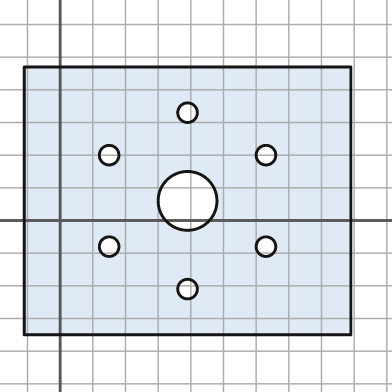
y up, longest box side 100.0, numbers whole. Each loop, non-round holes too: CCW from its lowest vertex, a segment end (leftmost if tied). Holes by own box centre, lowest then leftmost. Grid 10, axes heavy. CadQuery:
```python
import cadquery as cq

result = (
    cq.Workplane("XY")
    .moveTo(-11.0, -35.0)
    .lineTo(89.0, -35.0)
    .lineTo(89.0, 47.0)
    .lineTo(-11.0, 47.0)
    .close()
    .moveTo(39.0, -21.0)
    .circle(3.0)
    .moveTo(15.0, -8.0)
    .circle(3.0)
    .moveTo(63.0, -8.0)
    .circle(3.0)
    .moveTo(39.0, 6.0)
    .circle(9.0)
    .moveTo(15.0, 20.0)
    .circle(3.0)
    .moveTo(63.0, 20.0)
    .circle(3.0)
    .moveTo(39.0, 33.0)
    .circle(3.0)
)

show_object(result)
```